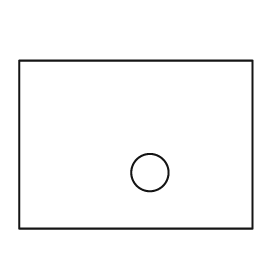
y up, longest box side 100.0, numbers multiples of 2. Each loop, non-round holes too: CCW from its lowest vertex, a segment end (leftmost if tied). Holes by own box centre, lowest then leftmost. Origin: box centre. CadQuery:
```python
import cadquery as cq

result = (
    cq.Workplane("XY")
    .moveTo(-50.0, -36.0)
    .lineTo(50.0, -36.0)
    .lineTo(50.0, 36.0)
    .lineTo(-50.0, 36.0)
    .close()
    .moveTo(6.0, -12.0)
    .circle(8.0)
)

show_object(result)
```